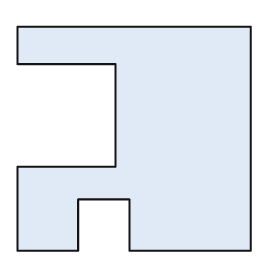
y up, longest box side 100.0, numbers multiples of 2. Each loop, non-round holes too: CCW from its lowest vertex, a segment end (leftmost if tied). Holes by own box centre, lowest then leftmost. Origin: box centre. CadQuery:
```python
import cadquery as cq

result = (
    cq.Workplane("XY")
    .moveTo(-50.0, -48.0)
    .lineTo(-24.0, -48.0)
    .lineTo(-24.0, -26.0)
    .lineTo(-2.0, -26.0)
    .lineTo(-2.0, -48.0)
    .lineTo(50.0, -48.0)
    .lineTo(50.0, 48.0)
    .lineTo(-50.0, 48.0)
    .lineTo(-50.0, 32.0)
    .lineTo(-8.0, 32.0)
    .lineTo(-8.0, -12.0)
    .lineTo(-50.0, -12.0)
    .close()
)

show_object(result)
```